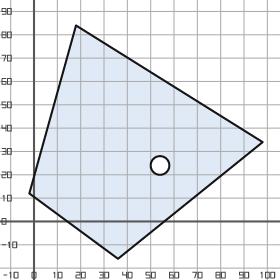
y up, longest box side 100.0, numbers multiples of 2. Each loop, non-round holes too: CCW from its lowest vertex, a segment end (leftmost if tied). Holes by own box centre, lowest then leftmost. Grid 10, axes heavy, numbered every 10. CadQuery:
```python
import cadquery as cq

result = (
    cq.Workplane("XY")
    .moveTo(36.0, -16.0)
    .lineTo(98.0, 34.0)
    .lineTo(18.0, 84.0)
    .lineTo(-2.0, 12.0)
    .close()
    .moveTo(54.0, 24.0)
    .circle(4.0)
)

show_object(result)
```